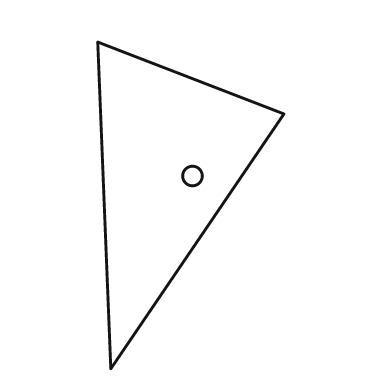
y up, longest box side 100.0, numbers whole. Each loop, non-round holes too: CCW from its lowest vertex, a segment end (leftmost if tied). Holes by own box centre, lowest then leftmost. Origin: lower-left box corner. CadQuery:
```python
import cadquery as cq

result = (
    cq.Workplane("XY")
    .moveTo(4.0, 0.0)
    .lineTo(57.0, 78.0)
    .lineTo(0.0, 100.0)
    .close()
    .moveTo(29.0, 59.0)
    .circle(3.0)
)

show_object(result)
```